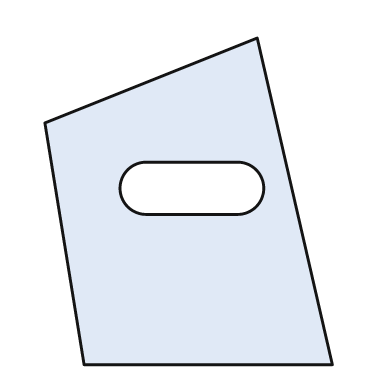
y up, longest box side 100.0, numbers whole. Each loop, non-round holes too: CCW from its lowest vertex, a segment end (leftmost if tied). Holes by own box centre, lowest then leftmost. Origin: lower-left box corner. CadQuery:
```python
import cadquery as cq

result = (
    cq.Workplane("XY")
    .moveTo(12.0, 0.0)
    .lineTo(88.0, 0.0)
    .lineTo(65.0, 100.0)
    .lineTo(0.0, 74.0)
    .close()
    .moveTo(31.0, 46.0)
    .lineTo(59.0, 46.0)
    .threePointArc((67.0, 54.0), (59.0, 62.0))
    .lineTo(31.0, 62.0)
    .threePointArc((23.0, 54.0), (31.0, 46.0))
    .close()
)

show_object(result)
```